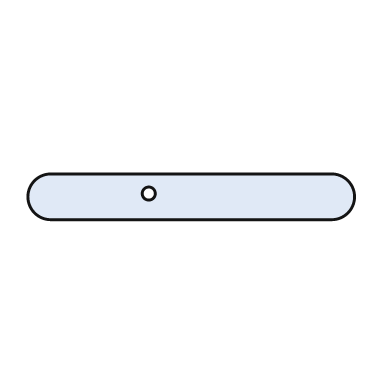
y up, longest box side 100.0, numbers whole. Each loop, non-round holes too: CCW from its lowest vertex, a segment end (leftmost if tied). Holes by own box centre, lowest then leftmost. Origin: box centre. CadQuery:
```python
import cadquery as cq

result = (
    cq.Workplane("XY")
    .moveTo(-43.0, -7.0)
    .lineTo(43.0, -7.0)
    .threePointArc((50.0, 0.0), (43.0, 7.0))
    .lineTo(-43.0, 7.0)
    .threePointArc((-50.0, 0.0), (-43.0, -7.0))
    .close()
    .moveTo(-13.0, 1.0)
    .circle(2.0)
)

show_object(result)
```